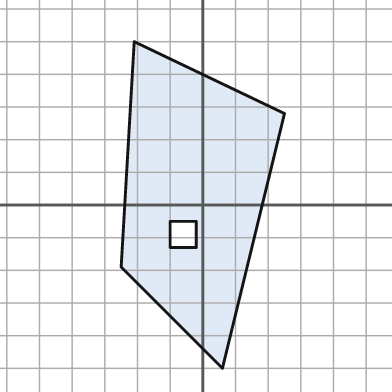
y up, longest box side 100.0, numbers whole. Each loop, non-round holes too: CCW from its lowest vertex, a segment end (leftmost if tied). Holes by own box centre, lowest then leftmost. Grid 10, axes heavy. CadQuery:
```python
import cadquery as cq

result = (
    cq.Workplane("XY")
    .moveTo(6.0, -50.0)
    .lineTo(25.0, 28.0)
    .lineTo(-21.0, 50.0)
    .lineTo(-25.0, -19.0)
    .close()
    .moveTo(-10.0, -13.0)
    .lineTo(-2.0, -13.0)
    .lineTo(-2.0, -5.0)
    .lineTo(-10.0, -5.0)
    .close()
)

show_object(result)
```